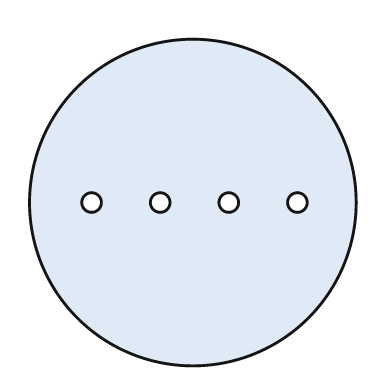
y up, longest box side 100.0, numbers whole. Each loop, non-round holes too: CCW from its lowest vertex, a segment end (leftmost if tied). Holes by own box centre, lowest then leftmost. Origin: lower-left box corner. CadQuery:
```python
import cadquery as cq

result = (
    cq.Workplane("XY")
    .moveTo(50.0, 50.0)
    .circle(50.0)
    .moveTo(19.0, 50.0)
    .circle(3.0)
    .moveTo(40.0, 50.0)
    .circle(3.0)
    .moveTo(61.0, 50.0)
    .circle(3.0)
    .moveTo(82.0, 50.0)
    .circle(3.0)
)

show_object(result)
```